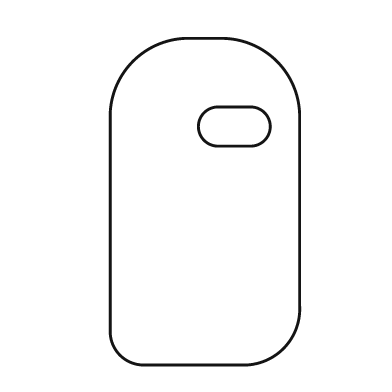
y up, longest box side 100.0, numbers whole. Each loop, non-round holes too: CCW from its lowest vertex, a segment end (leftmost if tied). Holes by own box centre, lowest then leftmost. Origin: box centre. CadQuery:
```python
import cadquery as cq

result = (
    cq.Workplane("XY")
    .moveTo(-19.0, -50.0)
    .lineTo(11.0, -50.0)
    .threePointArc((24.0, -45.0), (29.0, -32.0))
    .lineTo(29.0, 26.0)
    .threePointArc((22.0, 43.0), (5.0, 50.0))
    .lineTo(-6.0, 50.0)
    .threePointArc((-22.0, 43.0), (-29.0, 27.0))
    .lineTo(-29.0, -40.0)
    .threePointArc((-26.0, -47.0), (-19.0, -50.0))
    .close()
    .moveTo(4.0, 17.0)
    .lineTo(14.0, 17.0)
    .threePointArc((20.0, 23.0), (14.0, 29.0))
    .lineTo(4.0, 29.0)
    .threePointArc((-2.0, 23.0), (4.0, 17.0))
    .close()
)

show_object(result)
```